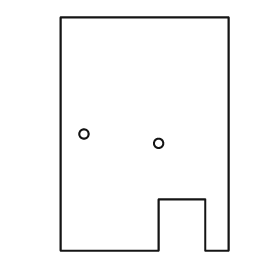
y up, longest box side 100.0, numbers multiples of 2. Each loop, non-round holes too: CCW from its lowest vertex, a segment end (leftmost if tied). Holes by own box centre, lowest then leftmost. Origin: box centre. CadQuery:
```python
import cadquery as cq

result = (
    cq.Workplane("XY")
    .moveTo(-36.0, -50.0)
    .lineTo(6.0, -50.0)
    .lineTo(6.0, -28.0)
    .lineTo(26.0, -28.0)
    .lineTo(26.0, -50.0)
    .lineTo(36.0, -50.0)
    .lineTo(36.0, 50.0)
    .lineTo(-36.0, 50.0)
    .close()
    .moveTo(6.0, -4.0)
    .circle(2.0)
    .moveTo(-26.0, 0.0)
    .circle(2.0)
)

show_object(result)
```